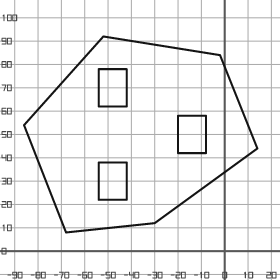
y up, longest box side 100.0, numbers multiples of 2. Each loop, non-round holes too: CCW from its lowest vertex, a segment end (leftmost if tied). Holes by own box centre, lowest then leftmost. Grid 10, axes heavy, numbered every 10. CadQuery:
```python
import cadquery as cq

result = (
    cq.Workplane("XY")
    .moveTo(-68.0, 8.0)
    .lineTo(-30.0, 12.0)
    .lineTo(14.0, 44.0)
    .lineTo(-2.0, 84.0)
    .lineTo(-52.0, 92.0)
    .lineTo(-86.0, 54.0)
    .close()
    .moveTo(-54.0, 22.0)
    .lineTo(-42.0, 22.0)
    .lineTo(-42.0, 38.0)
    .lineTo(-54.0, 38.0)
    .close()
    .moveTo(-20.0, 42.0)
    .lineTo(-8.0, 42.0)
    .lineTo(-8.0, 58.0)
    .lineTo(-20.0, 58.0)
    .close()
    .moveTo(-54.0, 62.0)
    .lineTo(-42.0, 62.0)
    .lineTo(-42.0, 78.0)
    .lineTo(-54.0, 78.0)
    .close()
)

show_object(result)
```